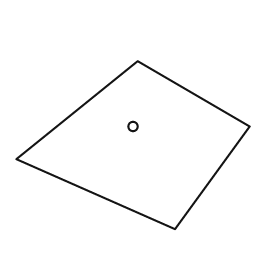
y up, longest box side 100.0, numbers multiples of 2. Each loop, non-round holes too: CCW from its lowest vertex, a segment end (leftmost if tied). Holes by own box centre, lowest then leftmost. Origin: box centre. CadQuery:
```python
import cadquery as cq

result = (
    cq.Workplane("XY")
    .moveTo(18.0, -36.0)
    .lineTo(50.0, 8.0)
    .lineTo(2.0, 36.0)
    .lineTo(-50.0, -6.0)
    .close()
    .moveTo(0.0, 8.0)
    .circle(2.0)
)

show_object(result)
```